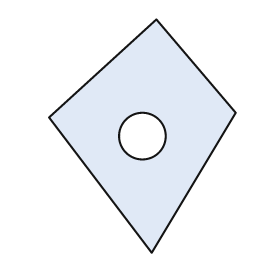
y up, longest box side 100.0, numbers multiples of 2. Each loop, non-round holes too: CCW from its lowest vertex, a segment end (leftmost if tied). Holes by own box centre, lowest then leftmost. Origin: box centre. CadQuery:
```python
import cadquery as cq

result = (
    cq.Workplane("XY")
    .moveTo(4.0, -50.0)
    .lineTo(40.0, 10.0)
    .lineTo(6.0, 50.0)
    .lineTo(-40.0, 8.0)
    .close()
    .moveTo(0.0, 0.0)
    .circle(10.0)
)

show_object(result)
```